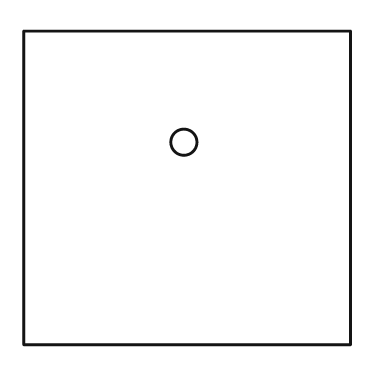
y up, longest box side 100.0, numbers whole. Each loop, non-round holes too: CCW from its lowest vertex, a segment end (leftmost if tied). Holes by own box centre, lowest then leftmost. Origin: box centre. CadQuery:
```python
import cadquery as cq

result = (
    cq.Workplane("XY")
    .moveTo(-50.0, -48.0)
    .lineTo(50.0, -48.0)
    .lineTo(50.0, 48.0)
    .lineTo(-50.0, 48.0)
    .close()
    .moveTo(-1.0, 14.0)
    .circle(4.0)
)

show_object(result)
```